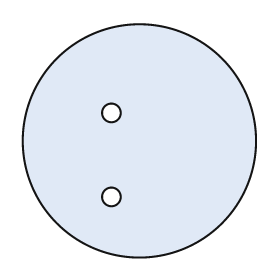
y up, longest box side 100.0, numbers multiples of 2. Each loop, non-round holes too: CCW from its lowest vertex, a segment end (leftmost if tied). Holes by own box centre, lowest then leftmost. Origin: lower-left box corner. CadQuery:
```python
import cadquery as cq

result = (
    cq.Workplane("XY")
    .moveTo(50.0, 50.0)
    .circle(50.0)
    .moveTo(38.0, 26.0)
    .circle(4.0)
    .moveTo(38.0, 62.0)
    .circle(4.0)
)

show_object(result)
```